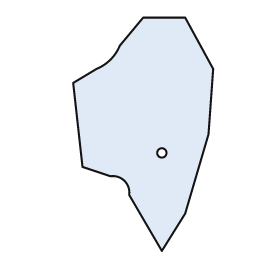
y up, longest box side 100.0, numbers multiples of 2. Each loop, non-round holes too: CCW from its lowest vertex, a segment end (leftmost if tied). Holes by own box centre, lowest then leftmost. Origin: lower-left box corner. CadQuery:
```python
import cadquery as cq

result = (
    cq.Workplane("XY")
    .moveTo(38.0, 0.0)
    .lineTo(48.0, 16.0)
    .lineTo(58.0, 50.0)
    .lineTo(60.0, 78.0)
    .lineTo(48.0, 100.0)
    .lineTo(30.0, 100.0)
    .lineTo(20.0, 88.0)
    .threePointArc((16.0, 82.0), (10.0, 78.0))
    .lineTo(0.0, 72.0)
    .lineTo(4.0, 36.0)
    .lineTo(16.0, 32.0)
    .threePointArc((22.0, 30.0), (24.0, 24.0))
    .close()
    .moveTo(38.0, 42.0)
    .circle(2.0)
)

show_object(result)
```